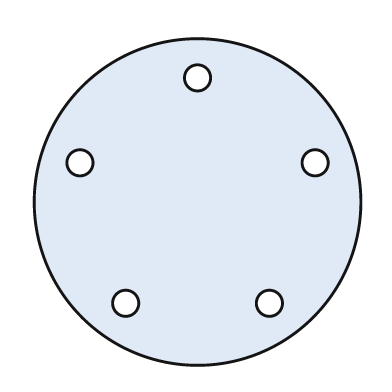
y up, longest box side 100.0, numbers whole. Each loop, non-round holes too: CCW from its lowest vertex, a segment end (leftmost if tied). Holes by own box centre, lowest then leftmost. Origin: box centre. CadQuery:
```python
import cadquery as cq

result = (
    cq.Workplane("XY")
    .moveTo(0.0, 0.0)
    .circle(50.0)
    .moveTo(-22.0, -31.0)
    .circle(4.0)
    .moveTo(22.0, -31.0)
    .circle(4.0)
    .moveTo(-36.0, 12.0)
    .circle(4.0)
    .moveTo(36.0, 12.0)
    .circle(4.0)
    .moveTo(0.0, 38.0)
    .circle(4.0)
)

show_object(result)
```